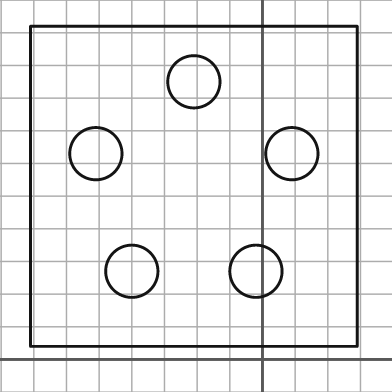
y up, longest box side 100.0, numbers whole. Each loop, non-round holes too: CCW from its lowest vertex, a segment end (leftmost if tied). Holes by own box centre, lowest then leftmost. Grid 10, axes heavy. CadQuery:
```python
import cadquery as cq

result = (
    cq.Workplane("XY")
    .moveTo(-71.0, 4.0)
    .lineTo(29.0, 4.0)
    .lineTo(29.0, 102.0)
    .lineTo(-71.0, 102.0)
    .close()
    .moveTo(-40.0, 27.0)
    .circle(8.0)
    .moveTo(-2.0, 27.0)
    .circle(8.0)
    .moveTo(-51.0, 63.0)
    .circle(8.0)
    .moveTo(9.0, 63.0)
    .circle(8.0)
    .moveTo(-21.0, 85.0)
    .circle(8.0)
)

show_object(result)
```